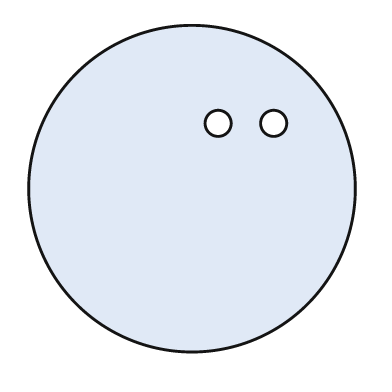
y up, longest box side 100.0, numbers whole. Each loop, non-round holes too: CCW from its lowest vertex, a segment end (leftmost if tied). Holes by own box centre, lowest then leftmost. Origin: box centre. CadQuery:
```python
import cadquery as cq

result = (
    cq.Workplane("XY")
    .moveTo(0.0, 0.0)
    .circle(50.0)
    .moveTo(8.0, 20.0)
    .circle(4.0)
    .moveTo(25.0, 20.0)
    .circle(4.0)
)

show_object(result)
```